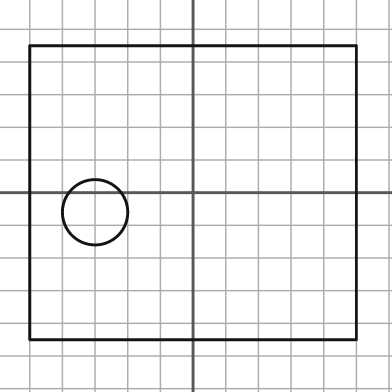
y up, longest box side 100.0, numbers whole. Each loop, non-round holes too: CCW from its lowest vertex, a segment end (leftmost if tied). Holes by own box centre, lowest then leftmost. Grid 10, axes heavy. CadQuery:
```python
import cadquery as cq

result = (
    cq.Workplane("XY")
    .moveTo(-50.0, -45.0)
    .lineTo(50.0, -45.0)
    .lineTo(50.0, 45.0)
    .lineTo(-50.0, 45.0)
    .close()
    .moveTo(-30.0, -6.0)
    .circle(10.0)
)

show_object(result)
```